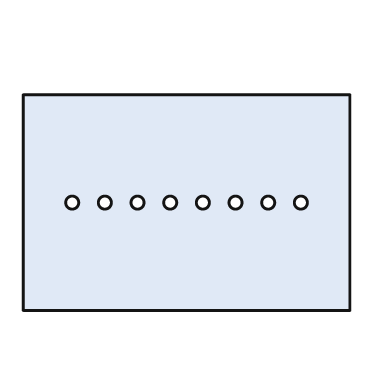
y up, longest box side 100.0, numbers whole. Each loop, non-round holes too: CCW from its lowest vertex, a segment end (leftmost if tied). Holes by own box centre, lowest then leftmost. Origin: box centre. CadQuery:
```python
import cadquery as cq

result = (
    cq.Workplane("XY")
    .moveTo(-50.0, -33.0)
    .lineTo(50.0, -33.0)
    .lineTo(50.0, 33.0)
    .lineTo(-50.0, 33.0)
    .close()
    .moveTo(-35.0, 0.0)
    .circle(2.0)
    .moveTo(-25.0, 0.0)
    .circle(2.0)
    .moveTo(-15.0, 0.0)
    .circle(2.0)
    .moveTo(-5.0, 0.0)
    .circle(2.0)
    .moveTo(5.0, 0.0)
    .circle(2.0)
    .moveTo(15.0, 0.0)
    .circle(2.0)
    .moveTo(25.0, 0.0)
    .circle(2.0)
    .moveTo(35.0, 0.0)
    .circle(2.0)
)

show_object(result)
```